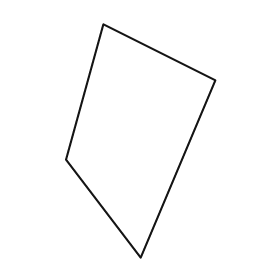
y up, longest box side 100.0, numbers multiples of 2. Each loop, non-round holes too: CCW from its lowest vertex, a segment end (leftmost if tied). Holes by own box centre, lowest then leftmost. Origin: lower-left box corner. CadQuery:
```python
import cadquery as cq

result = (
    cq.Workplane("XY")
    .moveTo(32.0, 0.0)
    .lineTo(64.0, 76.0)
    .lineTo(16.0, 100.0)
    .lineTo(0.0, 42.0)
    .close()
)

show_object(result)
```